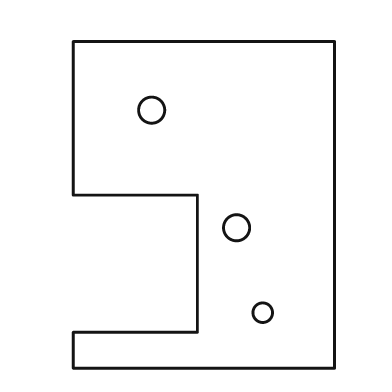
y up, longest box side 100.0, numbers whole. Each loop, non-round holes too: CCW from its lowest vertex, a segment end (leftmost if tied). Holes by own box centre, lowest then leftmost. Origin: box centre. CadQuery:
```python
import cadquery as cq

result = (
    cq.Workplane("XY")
    .moveTo(-40.0, -50.0)
    .lineTo(40.0, -50.0)
    .lineTo(40.0, 50.0)
    .lineTo(-40.0, 50.0)
    .lineTo(-40.0, 3.0)
    .lineTo(-2.0, 3.0)
    .lineTo(-2.0, -39.0)
    .lineTo(-40.0, -39.0)
    .close()
    .moveTo(18.0, -33.0)
    .circle(3.0)
    .moveTo(10.0, -7.0)
    .circle(4.0)
    .moveTo(-16.0, 29.0)
    .circle(4.0)
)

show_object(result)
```